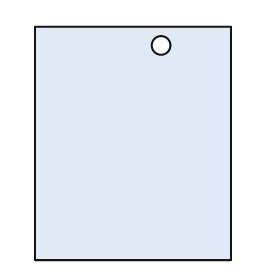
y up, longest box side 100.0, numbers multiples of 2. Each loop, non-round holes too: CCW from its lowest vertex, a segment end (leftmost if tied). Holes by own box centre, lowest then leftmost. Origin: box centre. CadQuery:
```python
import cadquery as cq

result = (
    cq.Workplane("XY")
    .moveTo(-42.0, -50.0)
    .lineTo(42.0, -50.0)
    .lineTo(42.0, 50.0)
    .lineTo(-42.0, 50.0)
    .close()
    .moveTo(12.0, 42.0)
    .circle(4.0)
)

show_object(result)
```